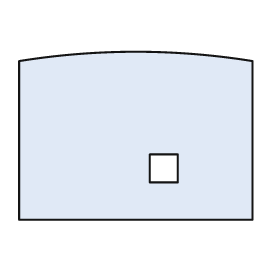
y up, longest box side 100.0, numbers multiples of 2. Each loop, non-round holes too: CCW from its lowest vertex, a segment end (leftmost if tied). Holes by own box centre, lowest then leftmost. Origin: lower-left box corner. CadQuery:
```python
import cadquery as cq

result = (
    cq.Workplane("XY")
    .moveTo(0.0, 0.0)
    .lineTo(100.0, 0.0)
    .lineTo(100.0, 68.0)
    .threePointArc((50.0, 72.0), (0.0, 68.0))
    .close()
    .moveTo(56.0, 16.0)
    .lineTo(68.0, 16.0)
    .lineTo(68.0, 28.0)
    .lineTo(56.0, 28.0)
    .close()
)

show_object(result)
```